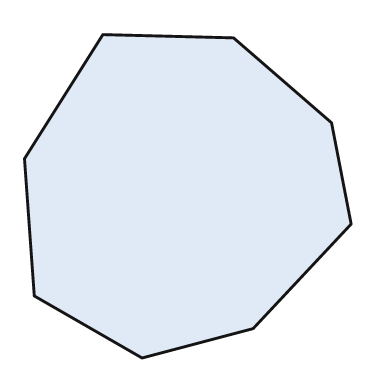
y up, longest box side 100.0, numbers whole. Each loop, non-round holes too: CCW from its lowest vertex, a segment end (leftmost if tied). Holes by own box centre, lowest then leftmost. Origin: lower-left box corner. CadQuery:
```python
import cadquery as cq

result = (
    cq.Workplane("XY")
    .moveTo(36.0, 0.0)
    .lineTo(70.0, 9.0)
    .lineTo(100.0, 41.0)
    .lineTo(94.0, 72.0)
    .lineTo(64.0, 98.0)
    .lineTo(24.0, 99.0)
    .lineTo(0.0, 61.0)
    .lineTo(3.0, 19.0)
    .close()
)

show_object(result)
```